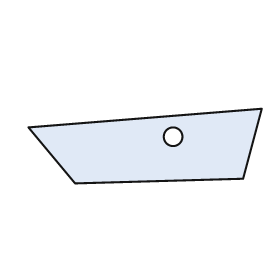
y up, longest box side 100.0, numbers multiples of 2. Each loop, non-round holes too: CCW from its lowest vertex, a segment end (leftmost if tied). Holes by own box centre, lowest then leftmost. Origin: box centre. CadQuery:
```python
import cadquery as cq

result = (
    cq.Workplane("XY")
    .moveTo(-30.0, -16.0)
    .lineTo(42.0, -14.0)
    .lineTo(50.0, 16.0)
    .lineTo(-50.0, 8.0)
    .close()
    .moveTo(12.0, 4.0)
    .circle(4.0)
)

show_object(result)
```